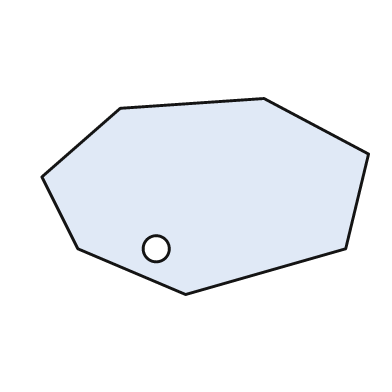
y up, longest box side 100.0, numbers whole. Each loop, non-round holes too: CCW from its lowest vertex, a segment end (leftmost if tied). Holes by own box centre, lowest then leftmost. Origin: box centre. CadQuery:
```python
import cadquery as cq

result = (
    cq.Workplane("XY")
    .moveTo(-6.0, -30.0)
    .lineTo(43.0, -16.0)
    .lineTo(50.0, 13.0)
    .lineTo(18.0, 30.0)
    .lineTo(-26.0, 27.0)
    .lineTo(-50.0, 6.0)
    .lineTo(-39.0, -16.0)
    .close()
    .moveTo(-15.0, -16.0)
    .circle(4.0)
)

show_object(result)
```